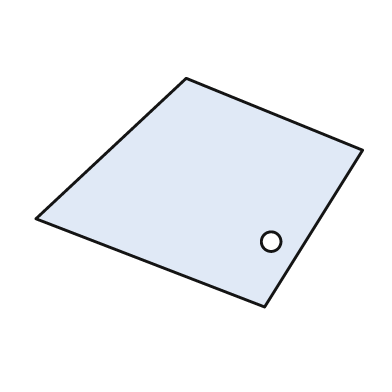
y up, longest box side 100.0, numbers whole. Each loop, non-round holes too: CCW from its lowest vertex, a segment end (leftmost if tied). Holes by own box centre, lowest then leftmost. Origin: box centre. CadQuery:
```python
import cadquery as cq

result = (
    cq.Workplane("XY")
    .moveTo(20.0, -35.0)
    .lineTo(50.0, 13.0)
    .lineTo(-4.0, 35.0)
    .lineTo(-50.0, -8.0)
    .close()
    .moveTo(22.0, -15.0)
    .circle(3.0)
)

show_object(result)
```